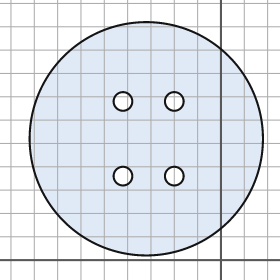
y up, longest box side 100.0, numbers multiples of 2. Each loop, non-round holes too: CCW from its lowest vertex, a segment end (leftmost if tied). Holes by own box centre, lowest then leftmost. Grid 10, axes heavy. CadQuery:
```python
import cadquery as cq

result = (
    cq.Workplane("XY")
    .moveTo(-32.0, 52.0)
    .circle(50.0)
    .moveTo(-42.0, 36.0)
    .circle(4.0)
    .moveTo(-20.0, 36.0)
    .circle(4.0)
    .moveTo(-42.0, 68.0)
    .circle(4.0)
    .moveTo(-20.0, 68.0)
    .circle(4.0)
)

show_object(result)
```